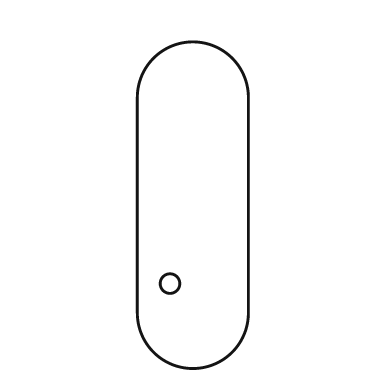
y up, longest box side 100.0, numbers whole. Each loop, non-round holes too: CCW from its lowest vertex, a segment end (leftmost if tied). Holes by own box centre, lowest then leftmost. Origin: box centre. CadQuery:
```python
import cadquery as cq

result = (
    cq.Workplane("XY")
    .moveTo(-17.0, -33.0)
    .threePointArc((0.0, -50.0), (17.0, -33.0))
    .lineTo(17.0, 33.0)
    .threePointArc((0.0, 50.0), (-17.0, 33.0))
    .close()
    .moveTo(-7.0, -24.0)
    .circle(3.0)
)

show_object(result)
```